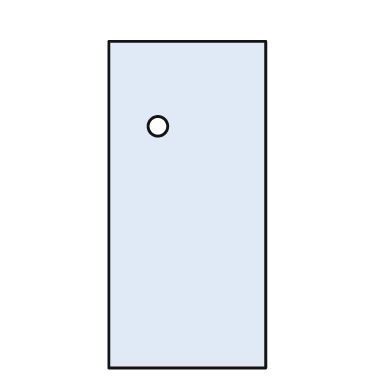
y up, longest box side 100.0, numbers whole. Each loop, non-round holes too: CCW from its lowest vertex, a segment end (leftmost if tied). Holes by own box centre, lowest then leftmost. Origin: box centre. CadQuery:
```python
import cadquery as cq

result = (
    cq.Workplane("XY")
    .moveTo(-24.0, -50.0)
    .lineTo(24.0, -50.0)
    .lineTo(24.0, 50.0)
    .lineTo(-24.0, 50.0)
    .close()
    .moveTo(-9.0, 24.0)
    .circle(3.0)
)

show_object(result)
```